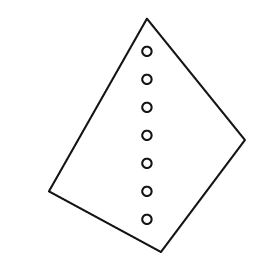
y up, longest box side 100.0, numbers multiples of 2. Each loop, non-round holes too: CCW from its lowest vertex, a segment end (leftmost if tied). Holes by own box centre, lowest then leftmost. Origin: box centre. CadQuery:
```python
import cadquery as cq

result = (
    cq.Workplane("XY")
    .moveTo(6.0, -50.0)
    .lineTo(42.0, -2.0)
    .lineTo(0.0, 50.0)
    .lineTo(-42.0, -24.0)
    .close()
    .moveTo(0.0, -36.0)
    .circle(2.0)
    .moveTo(0.0, -24.0)
    .circle(2.0)
    .moveTo(0.0, -12.0)
    .circle(2.0)
    .moveTo(0.0, 0.0)
    .circle(2.0)
    .moveTo(0.0, 12.0)
    .circle(2.0)
    .moveTo(0.0, 24.0)
    .circle(2.0)
    .moveTo(0.0, 36.0)
    .circle(2.0)
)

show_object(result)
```